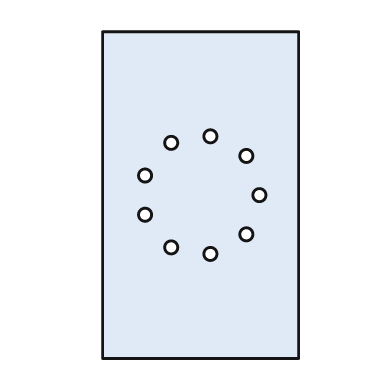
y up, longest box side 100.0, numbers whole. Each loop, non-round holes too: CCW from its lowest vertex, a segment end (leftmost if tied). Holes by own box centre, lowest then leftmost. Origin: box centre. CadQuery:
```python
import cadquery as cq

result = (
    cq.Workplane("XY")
    .moveTo(-30.0, -50.0)
    .lineTo(30.0, -50.0)
    .lineTo(30.0, 50.0)
    .lineTo(-30.0, 50.0)
    .close()
    .moveTo(3.0, -18.0)
    .circle(2.0)
    .moveTo(-9.0, -16.0)
    .circle(2.0)
    .moveTo(14.0, -12.0)
    .circle(2.0)
    .moveTo(-17.0, -6.0)
    .circle(2.0)
    .moveTo(18.0, 0.0)
    .circle(2.0)
    .moveTo(-17.0, 6.0)
    .circle(2.0)
    .moveTo(14.0, 12.0)
    .circle(2.0)
    .moveTo(-9.0, 16.0)
    .circle(2.0)
    .moveTo(3.0, 18.0)
    .circle(2.0)
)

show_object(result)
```